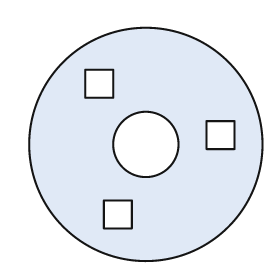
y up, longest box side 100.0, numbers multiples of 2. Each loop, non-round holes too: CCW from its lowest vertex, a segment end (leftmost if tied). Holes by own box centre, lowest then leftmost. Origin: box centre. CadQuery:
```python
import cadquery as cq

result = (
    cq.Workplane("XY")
    .moveTo(0.0, 0.0)
    .circle(50.0)
    .moveTo(-18.0, -36.0)
    .lineTo(-6.0, -36.0)
    .lineTo(-6.0, -24.0)
    .lineTo(-18.0, -24.0)
    .close()
    .moveTo(0.0, 0.0)
    .circle(14.0)
    .moveTo(26.0, -2.0)
    .lineTo(38.0, -2.0)
    .lineTo(38.0, 10.0)
    .lineTo(26.0, 10.0)
    .close()
    .moveTo(-26.0, 20.0)
    .lineTo(-14.0, 20.0)
    .lineTo(-14.0, 32.0)
    .lineTo(-26.0, 32.0)
    .close()
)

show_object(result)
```